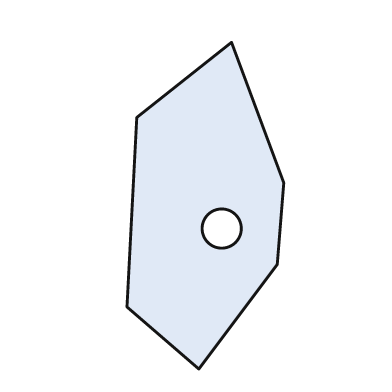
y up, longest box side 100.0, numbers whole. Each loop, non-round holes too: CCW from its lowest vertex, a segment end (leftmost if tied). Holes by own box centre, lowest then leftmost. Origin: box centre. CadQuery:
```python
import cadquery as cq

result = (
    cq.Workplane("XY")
    .moveTo(-2.0, -50.0)
    .lineTo(22.0, -18.0)
    .lineTo(24.0, 7.0)
    .lineTo(8.0, 50.0)
    .lineTo(-21.0, 27.0)
    .lineTo(-24.0, -31.0)
    .close()
    .moveTo(5.0, -7.0)
    .circle(6.0)
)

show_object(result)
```